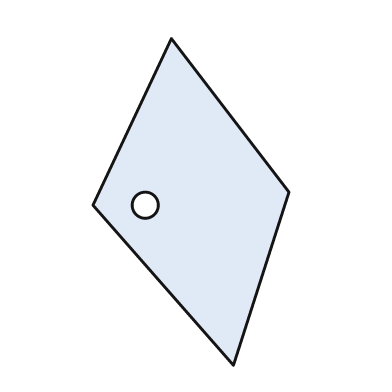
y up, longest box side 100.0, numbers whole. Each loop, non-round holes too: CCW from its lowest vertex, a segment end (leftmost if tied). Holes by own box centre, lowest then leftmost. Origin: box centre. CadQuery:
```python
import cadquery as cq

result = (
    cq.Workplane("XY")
    .moveTo(13.0, -50.0)
    .lineTo(30.0, 3.0)
    .lineTo(-6.0, 50.0)
    .lineTo(-30.0, -1.0)
    .close()
    .moveTo(-14.0, -1.0)
    .circle(4.0)
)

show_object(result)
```